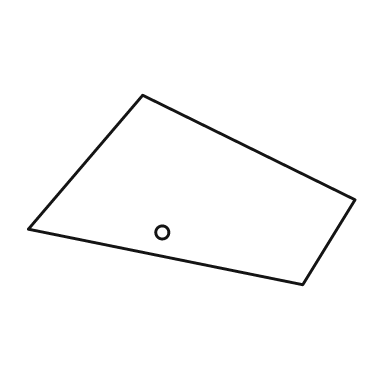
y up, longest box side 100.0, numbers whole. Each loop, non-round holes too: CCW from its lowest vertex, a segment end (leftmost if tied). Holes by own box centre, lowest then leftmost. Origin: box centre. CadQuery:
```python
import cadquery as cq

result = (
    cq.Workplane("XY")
    .moveTo(34.0, -29.0)
    .lineTo(50.0, -3.0)
    .lineTo(-15.0, 29.0)
    .lineTo(-50.0, -12.0)
    .close()
    .moveTo(-9.0, -13.0)
    .circle(2.0)
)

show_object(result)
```